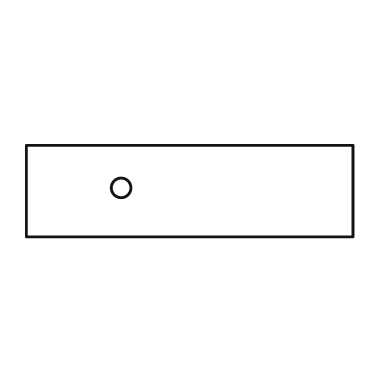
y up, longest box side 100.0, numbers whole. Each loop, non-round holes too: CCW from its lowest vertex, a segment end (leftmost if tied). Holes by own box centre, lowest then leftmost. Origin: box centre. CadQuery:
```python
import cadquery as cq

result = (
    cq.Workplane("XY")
    .moveTo(-50.0, -14.0)
    .lineTo(50.0, -14.0)
    .lineTo(50.0, 14.0)
    .lineTo(-50.0, 14.0)
    .close()
    .moveTo(-21.0, 1.0)
    .circle(3.0)
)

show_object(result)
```